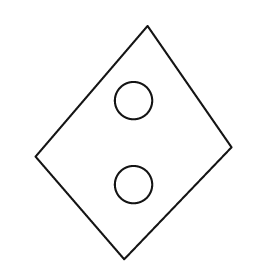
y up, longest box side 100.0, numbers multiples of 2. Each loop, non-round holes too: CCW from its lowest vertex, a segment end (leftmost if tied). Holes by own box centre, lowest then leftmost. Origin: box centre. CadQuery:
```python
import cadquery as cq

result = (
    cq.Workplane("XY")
    .moveTo(-4.0, -50.0)
    .lineTo(42.0, -2.0)
    .lineTo(6.0, 50.0)
    .lineTo(-42.0, -6.0)
    .close()
    .moveTo(0.0, -18.0)
    .circle(8.0)
    .moveTo(0.0, 18.0)
    .circle(8.0)
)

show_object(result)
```